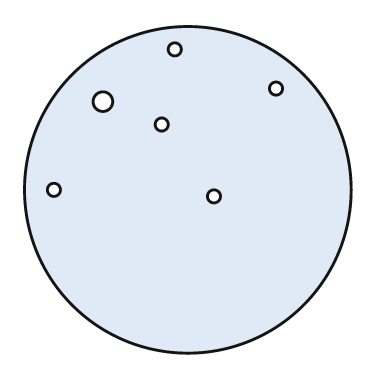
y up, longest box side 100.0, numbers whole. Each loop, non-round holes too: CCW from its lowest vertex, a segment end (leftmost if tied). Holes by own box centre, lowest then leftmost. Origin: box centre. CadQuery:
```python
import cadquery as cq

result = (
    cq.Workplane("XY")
    .moveTo(0.0, 0.0)
    .circle(50.0)
    .moveTo(8.0, -2.0)
    .circle(2.0)
    .moveTo(-41.0, 0.0)
    .circle(2.0)
    .moveTo(-8.0, 20.0)
    .circle(2.0)
    .moveTo(-26.0, 27.0)
    .circle(3.0)
    .moveTo(27.0, 31.0)
    .circle(2.0)
    .moveTo(-4.0, 43.0)
    .circle(2.0)
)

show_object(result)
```